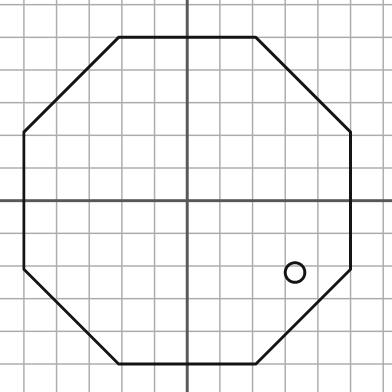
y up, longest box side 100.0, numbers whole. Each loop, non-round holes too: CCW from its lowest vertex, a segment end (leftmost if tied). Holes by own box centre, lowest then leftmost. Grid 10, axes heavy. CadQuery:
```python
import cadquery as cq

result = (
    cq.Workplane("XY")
    .moveTo(-21.0, -50.0)
    .lineTo(21.0, -50.0)
    .lineTo(50.0, -21.0)
    .lineTo(50.0, 21.0)
    .lineTo(21.0, 50.0)
    .lineTo(-21.0, 50.0)
    .lineTo(-50.0, 21.0)
    .lineTo(-50.0, -21.0)
    .close()
    .moveTo(33.0, -22.0)
    .circle(3.0)
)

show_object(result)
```